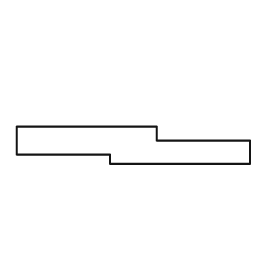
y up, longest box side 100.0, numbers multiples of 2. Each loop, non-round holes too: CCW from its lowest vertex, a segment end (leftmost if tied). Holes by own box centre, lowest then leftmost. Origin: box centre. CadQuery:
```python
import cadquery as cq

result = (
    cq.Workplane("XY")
    .moveTo(-10.0, -8.0)
    .lineTo(50.0, -8.0)
    .lineTo(50.0, 2.0)
    .lineTo(10.0, 2.0)
    .lineTo(10.0, 8.0)
    .lineTo(-50.0, 8.0)
    .lineTo(-50.0, -4.0)
    .lineTo(-10.0, -4.0)
    .close()
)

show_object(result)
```